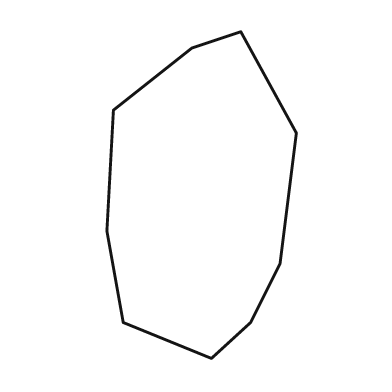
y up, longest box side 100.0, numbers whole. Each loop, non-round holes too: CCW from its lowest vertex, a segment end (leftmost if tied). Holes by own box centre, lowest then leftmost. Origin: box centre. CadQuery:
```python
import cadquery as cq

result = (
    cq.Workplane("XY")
    .moveTo(3.0, -50.0)
    .lineTo(15.0, -39.0)
    .lineTo(24.0, -21.0)
    .lineTo(29.0, 19.0)
    .lineTo(12.0, 50.0)
    .lineTo(-3.0, 45.0)
    .lineTo(-27.0, 26.0)
    .lineTo(-29.0, -11.0)
    .lineTo(-24.0, -39.0)
    .close()
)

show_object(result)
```